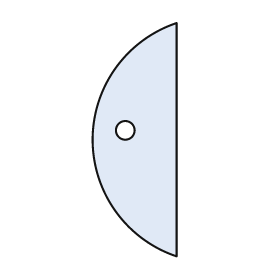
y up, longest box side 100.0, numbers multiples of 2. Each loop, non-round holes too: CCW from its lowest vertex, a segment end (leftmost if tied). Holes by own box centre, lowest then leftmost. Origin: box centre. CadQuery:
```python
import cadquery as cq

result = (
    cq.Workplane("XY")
    .moveTo(18.0, -50.0)
    .lineTo(18.0, 50.0)
    .threePointArc((-18.0, 0.0), (18.0, -50.0))
    .close()
    .moveTo(-4.0, 4.0)
    .circle(4.0)
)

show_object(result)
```